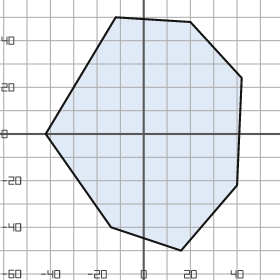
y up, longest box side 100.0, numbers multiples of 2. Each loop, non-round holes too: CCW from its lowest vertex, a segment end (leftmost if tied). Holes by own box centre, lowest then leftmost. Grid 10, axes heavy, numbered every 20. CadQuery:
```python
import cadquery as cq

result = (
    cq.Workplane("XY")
    .moveTo(16.0, -50.0)
    .lineTo(40.0, -22.0)
    .lineTo(42.0, 24.0)
    .lineTo(20.0, 48.0)
    .lineTo(-12.0, 50.0)
    .lineTo(-42.0, 0.0)
    .lineTo(-14.0, -40.0)
    .close()
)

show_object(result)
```